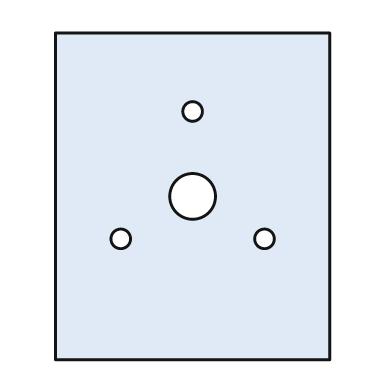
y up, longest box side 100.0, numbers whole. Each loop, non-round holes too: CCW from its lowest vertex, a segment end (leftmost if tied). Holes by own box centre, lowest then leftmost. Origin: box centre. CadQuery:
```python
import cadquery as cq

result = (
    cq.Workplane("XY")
    .moveTo(-42.0, -50.0)
    .lineTo(42.0, -50.0)
    .lineTo(42.0, 50.0)
    .lineTo(-42.0, 50.0)
    .close()
    .moveTo(-22.0, -13.0)
    .circle(3.0)
    .moveTo(22.0, -13.0)
    .circle(3.0)
    .moveTo(0.0, 0.0)
    .circle(7.0)
    .moveTo(0.0, 26.0)
    .circle(3.0)
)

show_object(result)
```